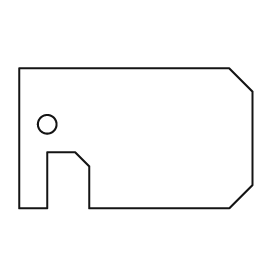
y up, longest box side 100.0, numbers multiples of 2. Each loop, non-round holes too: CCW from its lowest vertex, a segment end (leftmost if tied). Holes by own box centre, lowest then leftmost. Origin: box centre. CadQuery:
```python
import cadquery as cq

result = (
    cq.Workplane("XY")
    .moveTo(-50.0, -30.0)
    .lineTo(-38.0, -30.0)
    .lineTo(-38.0, -6.0)
    .lineTo(-26.0, -6.0)
    .lineTo(-20.0, -12.0)
    .lineTo(-20.0, -30.0)
    .lineTo(40.0, -30.0)
    .lineTo(50.0, -20.0)
    .lineTo(50.0, 20.0)
    .lineTo(40.0, 30.0)
    .lineTo(-50.0, 30.0)
    .close()
    .moveTo(-38.0, 6.0)
    .circle(4.0)
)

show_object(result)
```